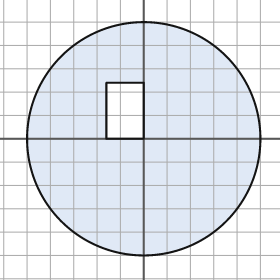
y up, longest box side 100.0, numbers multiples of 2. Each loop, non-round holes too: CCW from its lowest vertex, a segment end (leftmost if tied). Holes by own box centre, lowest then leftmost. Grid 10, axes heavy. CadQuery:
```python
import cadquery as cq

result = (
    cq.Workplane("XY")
    .moveTo(0.0, 0.0)
    .circle(50.0)
    .moveTo(-16.0, 0.0)
    .lineTo(0.0, 0.0)
    .lineTo(0.0, 24.0)
    .lineTo(-16.0, 24.0)
    .close()
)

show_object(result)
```